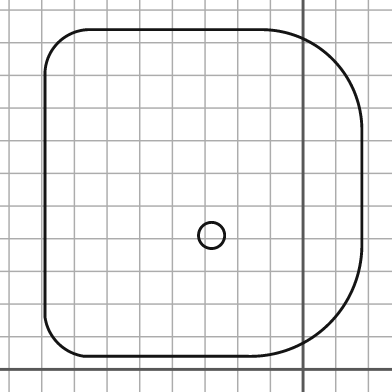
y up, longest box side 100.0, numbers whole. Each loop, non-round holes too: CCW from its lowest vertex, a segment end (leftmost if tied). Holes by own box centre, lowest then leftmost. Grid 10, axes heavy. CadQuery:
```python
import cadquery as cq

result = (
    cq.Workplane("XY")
    .moveTo(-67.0, 4.0)
    .lineTo(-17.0, 4.0)
    .threePointArc((8.0, 14.0), (18.0, 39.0))
    .lineTo(18.0, 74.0)
    .threePointArc((9.0, 95.0), (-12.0, 104.0))
    .lineTo(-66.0, 104.0)
    .threePointArc((-75.0, 100.0), (-79.0, 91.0))
    .lineTo(-79.0, 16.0)
    .threePointArc((-75.0, 8.0), (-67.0, 4.0))
    .close()
    .moveTo(-28.0, 41.0)
    .circle(4.0)
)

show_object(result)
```